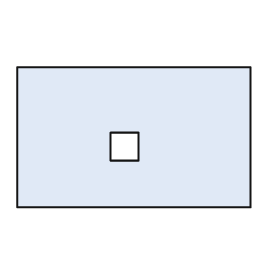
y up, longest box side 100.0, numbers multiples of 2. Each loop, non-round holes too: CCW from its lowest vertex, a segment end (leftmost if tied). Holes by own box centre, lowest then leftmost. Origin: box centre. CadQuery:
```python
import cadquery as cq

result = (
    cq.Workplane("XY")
    .moveTo(-50.0, -30.0)
    .lineTo(50.0, -30.0)
    .lineTo(50.0, 30.0)
    .lineTo(-50.0, 30.0)
    .close()
    .moveTo(-10.0, -10.0)
    .lineTo(2.0, -10.0)
    .lineTo(2.0, 2.0)
    .lineTo(-10.0, 2.0)
    .close()
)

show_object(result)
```